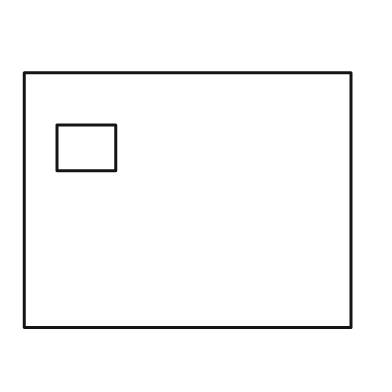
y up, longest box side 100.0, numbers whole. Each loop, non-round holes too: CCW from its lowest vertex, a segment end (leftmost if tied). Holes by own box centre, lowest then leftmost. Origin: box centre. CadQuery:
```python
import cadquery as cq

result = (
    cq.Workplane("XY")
    .moveTo(-50.0, -39.0)
    .lineTo(50.0, -39.0)
    .lineTo(50.0, 39.0)
    .lineTo(-50.0, 39.0)
    .close()
    .moveTo(-40.0, 9.0)
    .lineTo(-22.0, 9.0)
    .lineTo(-22.0, 23.0)
    .lineTo(-40.0, 23.0)
    .close()
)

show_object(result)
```